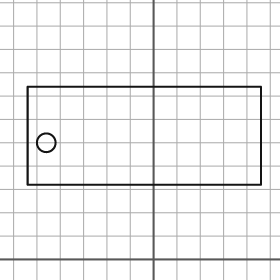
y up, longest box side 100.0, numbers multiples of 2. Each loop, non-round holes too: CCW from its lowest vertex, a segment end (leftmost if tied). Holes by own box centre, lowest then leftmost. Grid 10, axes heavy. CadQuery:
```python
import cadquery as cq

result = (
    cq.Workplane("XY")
    .moveTo(-54.0, 32.0)
    .lineTo(46.0, 32.0)
    .lineTo(46.0, 74.0)
    .lineTo(-54.0, 74.0)
    .close()
    .moveTo(-46.0, 50.0)
    .circle(4.0)
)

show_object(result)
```